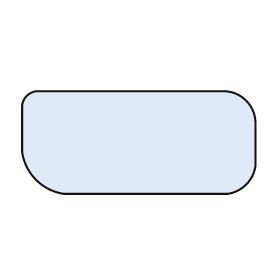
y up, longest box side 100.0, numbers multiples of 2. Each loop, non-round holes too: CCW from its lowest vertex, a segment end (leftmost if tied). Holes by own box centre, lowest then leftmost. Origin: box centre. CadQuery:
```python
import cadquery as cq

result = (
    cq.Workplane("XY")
    .moveTo(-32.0, -22.0)
    .lineTo(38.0, -22.0)
    .threePointArc((46.0, -18.0), (50.0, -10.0))
    .lineTo(50.0, 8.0)
    .threePointArc((46.0, 18.0), (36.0, 22.0))
    .lineTo(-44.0, 22.0)
    .threePointArc((-48.0, 20.0), (-50.0, 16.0))
    .lineTo(-50.0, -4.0)
    .threePointArc((-44.0, -16.0), (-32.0, -22.0))
    .close()
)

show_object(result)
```